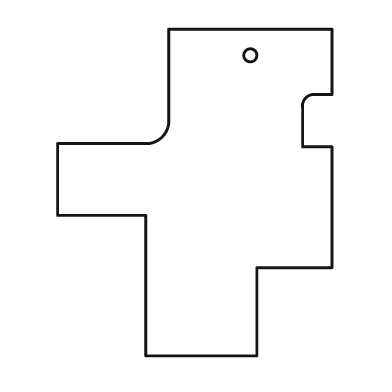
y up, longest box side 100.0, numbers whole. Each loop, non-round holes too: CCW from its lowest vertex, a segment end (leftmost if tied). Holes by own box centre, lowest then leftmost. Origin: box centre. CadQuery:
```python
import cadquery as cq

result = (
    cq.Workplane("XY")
    .moveTo(-15.0, -50.0)
    .lineTo(19.0, -50.0)
    .lineTo(19.0, -23.0)
    .lineTo(42.0, -23.0)
    .lineTo(42.0, 14.0)
    .lineTo(33.0, 14.0)
    .lineTo(33.0, 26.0)
    .threePointArc((34.0, 29.0), (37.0, 30.0))
    .lineTo(42.0, 30.0)
    .lineTo(42.0, 50.0)
    .lineTo(-8.0, 50.0)
    .lineTo(-8.0, 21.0)
    .threePointArc((-10.0, 17.0), (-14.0, 15.0))
    .lineTo(-42.0, 15.0)
    .lineTo(-42.0, -7.0)
    .lineTo(-15.0, -7.0)
    .close()
    .moveTo(17.0, 42.0)
    .circle(2.0)
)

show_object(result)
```